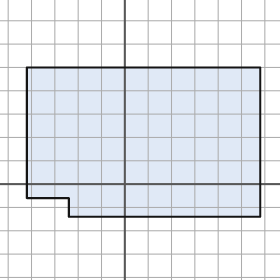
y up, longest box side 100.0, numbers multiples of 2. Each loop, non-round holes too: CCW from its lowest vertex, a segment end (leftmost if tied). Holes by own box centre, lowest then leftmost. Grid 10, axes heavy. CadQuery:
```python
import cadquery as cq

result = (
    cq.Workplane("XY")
    .moveTo(-24.0, -14.0)
    .lineTo(58.0, -14.0)
    .lineTo(58.0, 50.0)
    .lineTo(-42.0, 50.0)
    .lineTo(-42.0, -6.0)
    .lineTo(-24.0, -6.0)
    .close()
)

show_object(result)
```